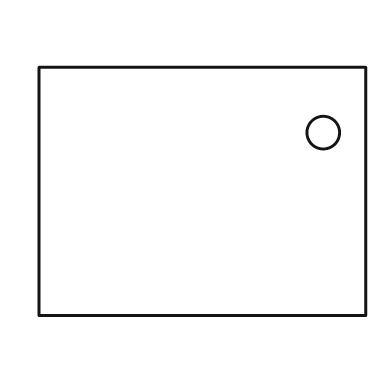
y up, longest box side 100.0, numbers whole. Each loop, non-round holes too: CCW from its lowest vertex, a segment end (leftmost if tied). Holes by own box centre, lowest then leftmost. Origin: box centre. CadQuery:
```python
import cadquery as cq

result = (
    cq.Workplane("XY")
    .moveTo(-50.0, -38.0)
    .lineTo(50.0, -38.0)
    .lineTo(50.0, 38.0)
    .lineTo(-50.0, 38.0)
    .close()
    .moveTo(37.0, 18.0)
    .circle(5.0)
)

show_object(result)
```